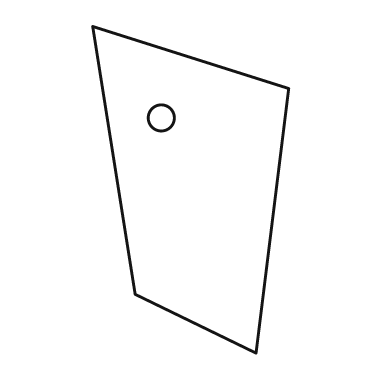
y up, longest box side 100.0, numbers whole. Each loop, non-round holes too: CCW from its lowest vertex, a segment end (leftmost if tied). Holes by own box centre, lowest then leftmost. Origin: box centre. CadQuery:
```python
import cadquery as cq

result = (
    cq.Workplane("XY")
    .moveTo(20.0, -50.0)
    .lineTo(30.0, 31.0)
    .lineTo(-30.0, 50.0)
    .lineTo(-17.0, -32.0)
    .close()
    .moveTo(-9.0, 22.0)
    .circle(4.0)
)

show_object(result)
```